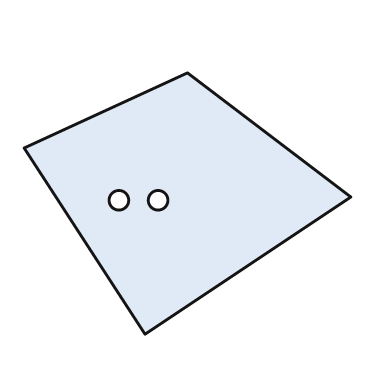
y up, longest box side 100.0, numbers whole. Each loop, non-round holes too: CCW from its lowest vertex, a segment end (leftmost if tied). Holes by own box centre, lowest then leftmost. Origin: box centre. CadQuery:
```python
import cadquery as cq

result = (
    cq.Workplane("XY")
    .moveTo(-13.0, -40.0)
    .lineTo(50.0, 2.0)
    .lineTo(0.0, 40.0)
    .lineTo(-50.0, 17.0)
    .close()
    .moveTo(-21.0, 1.0)
    .circle(3.0)
    .moveTo(-9.0, 1.0)
    .circle(3.0)
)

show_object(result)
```